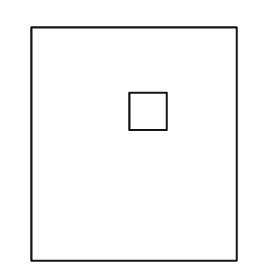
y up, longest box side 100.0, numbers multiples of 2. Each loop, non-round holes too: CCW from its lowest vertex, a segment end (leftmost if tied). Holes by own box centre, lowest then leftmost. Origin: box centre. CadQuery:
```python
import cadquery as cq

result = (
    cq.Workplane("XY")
    .moveTo(-44.0, -50.0)
    .lineTo(44.0, -50.0)
    .lineTo(44.0, 50.0)
    .lineTo(-44.0, 50.0)
    .close()
    .moveTo(-2.0, 6.0)
    .lineTo(14.0, 6.0)
    .lineTo(14.0, 22.0)
    .lineTo(-2.0, 22.0)
    .close()
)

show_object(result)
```